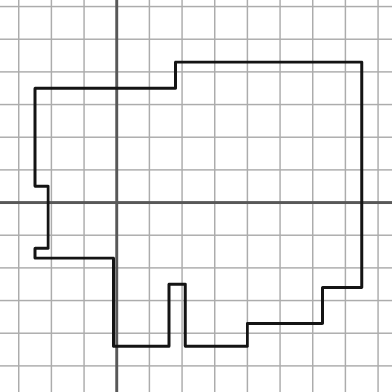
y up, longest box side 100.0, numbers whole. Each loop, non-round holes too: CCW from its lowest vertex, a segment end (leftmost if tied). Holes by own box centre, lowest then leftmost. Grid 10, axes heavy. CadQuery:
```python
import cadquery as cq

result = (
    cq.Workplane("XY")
    .moveTo(-1.0, -44.0)
    .lineTo(16.0, -44.0)
    .lineTo(16.0, -25.0)
    .lineTo(21.0, -25.0)
    .lineTo(21.0, -44.0)
    .lineTo(40.0, -44.0)
    .lineTo(40.0, -37.0)
    .lineTo(63.0, -37.0)
    .lineTo(63.0, -26.0)
    .lineTo(75.0, -26.0)
    .lineTo(75.0, 43.0)
    .lineTo(18.0, 43.0)
    .lineTo(18.0, 35.0)
    .lineTo(-25.0, 35.0)
    .lineTo(-25.0, 5.0)
    .lineTo(-21.0, 5.0)
    .lineTo(-21.0, -14.0)
    .lineTo(-25.0, -14.0)
    .lineTo(-25.0, -17.0)
    .lineTo(-1.0, -17.0)
    .close()
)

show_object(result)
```